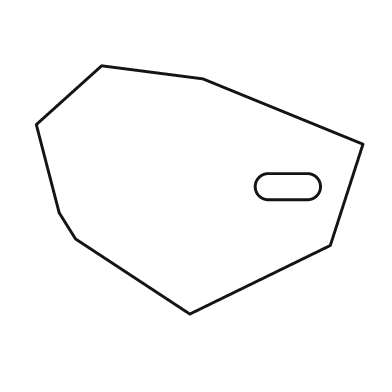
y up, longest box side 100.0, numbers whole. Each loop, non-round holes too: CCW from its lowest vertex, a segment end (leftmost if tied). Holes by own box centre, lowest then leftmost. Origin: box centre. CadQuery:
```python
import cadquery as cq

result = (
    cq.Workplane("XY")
    .moveTo(-3.0, -38.0)
    .lineTo(40.0, -17.0)
    .lineTo(50.0, 14.0)
    .lineTo(1.0, 34.0)
    .lineTo(-30.0, 38.0)
    .lineTo(-50.0, 20.0)
    .lineTo(-43.0, -7.0)
    .lineTo(-38.0, -15.0)
    .close()
    .moveTo(21.0, -3.0)
    .lineTo(33.0, -3.0)
    .threePointArc((37.0, 1.0), (33.0, 5.0))
    .lineTo(21.0, 5.0)
    .threePointArc((17.0, 1.0), (21.0, -3.0))
    .close()
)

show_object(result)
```